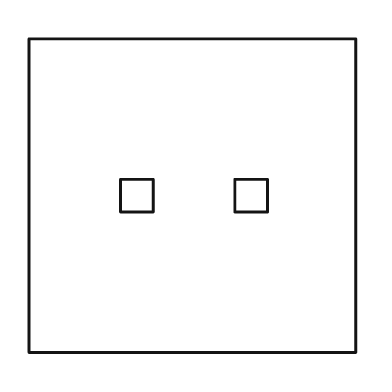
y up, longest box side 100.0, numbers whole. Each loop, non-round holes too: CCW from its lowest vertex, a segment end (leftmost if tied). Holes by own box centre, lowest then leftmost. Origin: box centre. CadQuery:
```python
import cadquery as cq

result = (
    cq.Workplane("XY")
    .moveTo(-50.0, -48.0)
    .lineTo(50.0, -48.0)
    .lineTo(50.0, 48.0)
    .lineTo(-50.0, 48.0)
    .close()
    .moveTo(-22.0, -5.0)
    .lineTo(-12.0, -5.0)
    .lineTo(-12.0, 5.0)
    .lineTo(-22.0, 5.0)
    .close()
    .moveTo(13.0, -5.0)
    .lineTo(23.0, -5.0)
    .lineTo(23.0, 5.0)
    .lineTo(13.0, 5.0)
    .close()
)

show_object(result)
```